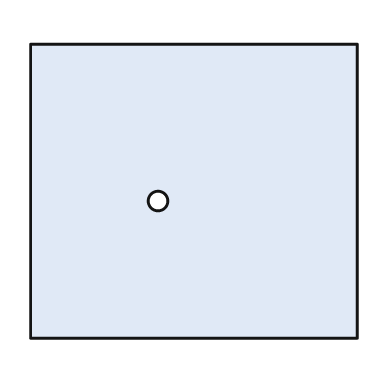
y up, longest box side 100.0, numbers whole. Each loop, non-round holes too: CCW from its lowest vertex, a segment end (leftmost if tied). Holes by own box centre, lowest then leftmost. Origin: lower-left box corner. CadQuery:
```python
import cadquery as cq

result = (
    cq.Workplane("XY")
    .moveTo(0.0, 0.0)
    .lineTo(100.0, 0.0)
    .lineTo(100.0, 90.0)
    .lineTo(0.0, 90.0)
    .close()
    .moveTo(39.0, 42.0)
    .circle(3.0)
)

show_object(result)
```